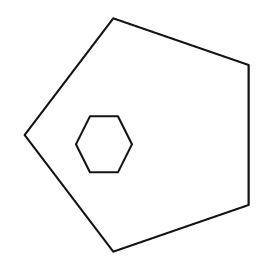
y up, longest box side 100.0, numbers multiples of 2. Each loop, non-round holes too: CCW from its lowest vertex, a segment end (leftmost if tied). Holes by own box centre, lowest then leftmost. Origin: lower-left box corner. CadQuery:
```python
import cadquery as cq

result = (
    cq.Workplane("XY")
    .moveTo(38.0, 0.0)
    .lineTo(96.0, 20.0)
    .lineTo(96.0, 80.0)
    .lineTo(38.0, 100.0)
    .lineTo(0.0, 50.0)
    .close()
    .moveTo(28.0, 34.0)
    .lineTo(40.0, 34.0)
    .lineTo(46.0, 46.0)
    .lineTo(40.0, 58.0)
    .lineTo(28.0, 58.0)
    .lineTo(22.0, 46.0)
    .close()
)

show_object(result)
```